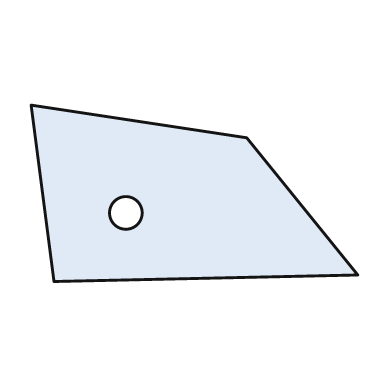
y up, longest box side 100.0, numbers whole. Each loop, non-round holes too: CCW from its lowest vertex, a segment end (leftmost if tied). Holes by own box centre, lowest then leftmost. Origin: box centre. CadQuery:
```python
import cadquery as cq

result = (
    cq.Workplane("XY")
    .moveTo(-43.0, -27.0)
    .lineTo(50.0, -25.0)
    .lineTo(16.0, 17.0)
    .lineTo(-50.0, 27.0)
    .close()
    .moveTo(-21.0, -6.0)
    .circle(5.0)
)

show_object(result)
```